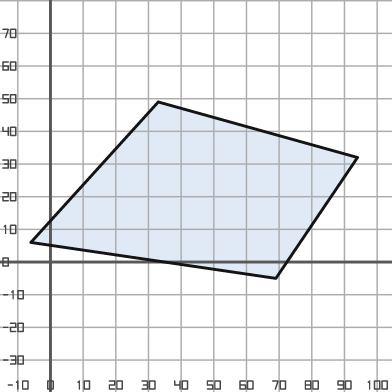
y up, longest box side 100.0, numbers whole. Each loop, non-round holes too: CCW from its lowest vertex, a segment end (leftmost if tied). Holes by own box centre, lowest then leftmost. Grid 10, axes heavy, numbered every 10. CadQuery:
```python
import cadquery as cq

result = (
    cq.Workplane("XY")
    .moveTo(69.0, -5.0)
    .lineTo(94.0, 32.0)
    .lineTo(33.0, 49.0)
    .lineTo(-6.0, 6.0)
    .close()
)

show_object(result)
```